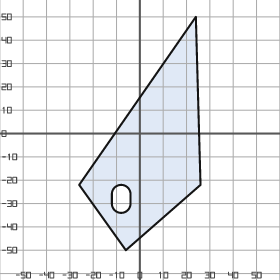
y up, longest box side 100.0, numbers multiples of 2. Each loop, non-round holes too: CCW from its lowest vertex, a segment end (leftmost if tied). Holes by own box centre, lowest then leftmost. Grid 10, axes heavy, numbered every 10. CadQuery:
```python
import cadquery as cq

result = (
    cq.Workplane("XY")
    .moveTo(-6.0, -50.0)
    .lineTo(26.0, -22.0)
    .lineTo(24.0, 50.0)
    .lineTo(-26.0, -22.0)
    .close()
    .moveTo(-12.0, -30.0)
    .threePointArc((-8.0, -34.0), (-4.0, -30.0))
    .lineTo(-4.0, -26.0)
    .threePointArc((-8.0, -22.0), (-12.0, -26.0))
    .close()
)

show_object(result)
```